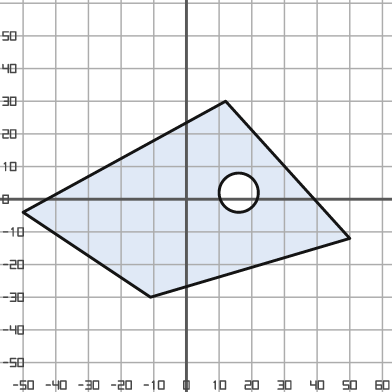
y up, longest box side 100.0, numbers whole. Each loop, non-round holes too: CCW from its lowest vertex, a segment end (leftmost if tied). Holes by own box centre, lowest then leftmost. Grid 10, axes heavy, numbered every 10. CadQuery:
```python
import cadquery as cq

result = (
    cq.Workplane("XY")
    .moveTo(-11.0, -30.0)
    .lineTo(50.0, -12.0)
    .lineTo(12.0, 30.0)
    .lineTo(-50.0, -4.0)
    .close()
    .moveTo(16.0, 2.0)
    .circle(6.0)
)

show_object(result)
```